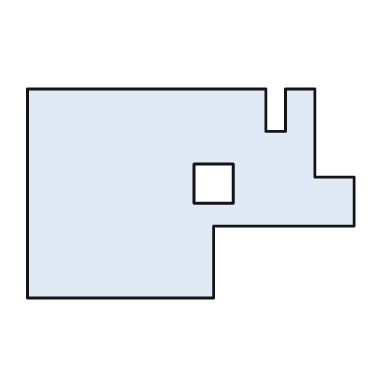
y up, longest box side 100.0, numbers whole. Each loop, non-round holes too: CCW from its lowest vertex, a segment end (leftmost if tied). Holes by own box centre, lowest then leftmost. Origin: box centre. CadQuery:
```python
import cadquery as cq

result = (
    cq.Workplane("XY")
    .moveTo(-50.0, -32.0)
    .lineTo(7.0, -32.0)
    .lineTo(7.0, -10.0)
    .lineTo(50.0, -10.0)
    .lineTo(50.0, 5.0)
    .lineTo(38.0, 5.0)
    .lineTo(38.0, 32.0)
    .lineTo(29.0, 32.0)
    .lineTo(29.0, 19.0)
    .lineTo(23.0, 19.0)
    .lineTo(23.0, 32.0)
    .lineTo(-50.0, 32.0)
    .close()
    .moveTo(1.0, -3.0)
    .lineTo(13.0, -3.0)
    .lineTo(13.0, 9.0)
    .lineTo(1.0, 9.0)
    .close()
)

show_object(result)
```